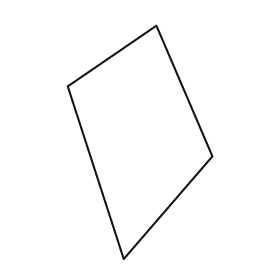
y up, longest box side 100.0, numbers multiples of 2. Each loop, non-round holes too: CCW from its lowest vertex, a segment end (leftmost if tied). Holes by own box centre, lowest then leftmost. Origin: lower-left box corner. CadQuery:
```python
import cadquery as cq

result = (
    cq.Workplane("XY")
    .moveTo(24.0, 0.0)
    .lineTo(62.0, 44.0)
    .lineTo(38.0, 100.0)
    .lineTo(0.0, 74.0)
    .close()
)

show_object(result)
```